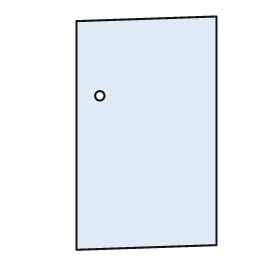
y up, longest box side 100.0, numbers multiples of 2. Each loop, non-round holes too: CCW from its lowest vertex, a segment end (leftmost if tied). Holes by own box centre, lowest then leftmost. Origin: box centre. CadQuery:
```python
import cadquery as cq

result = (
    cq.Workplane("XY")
    .moveTo(-30.0, -50.0)
    .lineTo(30.0, -48.0)
    .lineTo(30.0, 50.0)
    .lineTo(-30.0, 48.0)
    .close()
    .moveTo(-20.0, 16.0)
    .circle(2.0)
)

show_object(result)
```